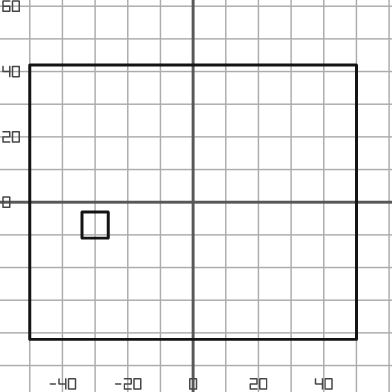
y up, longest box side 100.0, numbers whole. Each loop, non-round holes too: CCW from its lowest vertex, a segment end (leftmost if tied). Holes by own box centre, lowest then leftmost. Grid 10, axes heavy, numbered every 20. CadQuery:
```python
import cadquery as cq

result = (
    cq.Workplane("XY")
    .moveTo(-50.0, -42.0)
    .lineTo(50.0, -42.0)
    .lineTo(50.0, 42.0)
    .lineTo(-50.0, 42.0)
    .close()
    .moveTo(-34.0, -11.0)
    .lineTo(-26.0, -11.0)
    .lineTo(-26.0, -3.0)
    .lineTo(-34.0, -3.0)
    .close()
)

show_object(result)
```